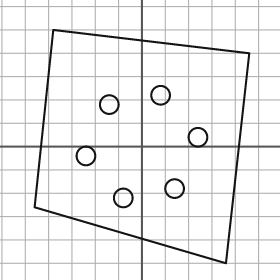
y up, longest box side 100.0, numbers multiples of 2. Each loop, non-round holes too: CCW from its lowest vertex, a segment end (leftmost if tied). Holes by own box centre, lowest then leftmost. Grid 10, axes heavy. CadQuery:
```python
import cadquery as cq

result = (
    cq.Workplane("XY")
    .moveTo(36.0, -50.0)
    .lineTo(46.0, 40.0)
    .lineTo(-38.0, 50.0)
    .lineTo(-46.0, -26.0)
    .close()
    .moveTo(-8.0, -22.0)
    .circle(4.0)
    .moveTo(14.0, -18.0)
    .circle(4.0)
    .moveTo(-24.0, -4.0)
    .circle(4.0)
    .moveTo(24.0, 4.0)
    .circle(4.0)
    .moveTo(-14.0, 18.0)
    .circle(4.0)
    .moveTo(8.0, 22.0)
    .circle(4.0)
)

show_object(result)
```